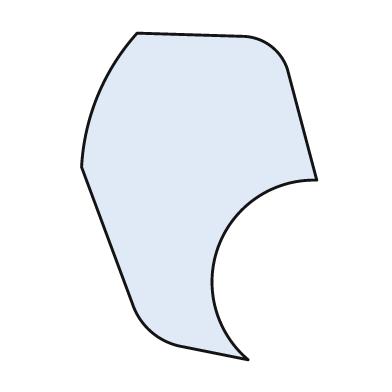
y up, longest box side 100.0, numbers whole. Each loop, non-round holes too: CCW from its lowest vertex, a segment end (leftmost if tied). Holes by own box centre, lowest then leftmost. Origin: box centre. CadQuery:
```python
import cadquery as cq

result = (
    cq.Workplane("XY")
    .moveTo(15.0, -50.0)
    .threePointArc((6.0, -15.0), (36.0, 5.0))
    .lineTo(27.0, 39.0)
    .threePointArc((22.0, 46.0), (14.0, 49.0))
    .lineTo(-19.0, 50.0)
    .threePointArc((-31.0, 31.0), (-36.0, 9.0))
    .lineTo(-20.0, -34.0)
    .threePointArc((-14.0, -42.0), (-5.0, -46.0))
    .close()
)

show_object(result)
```